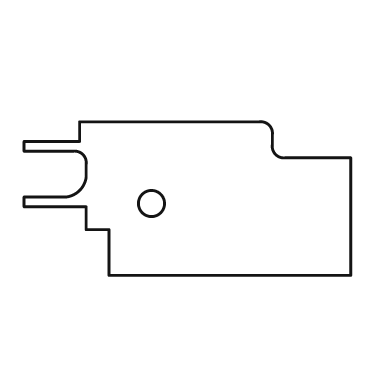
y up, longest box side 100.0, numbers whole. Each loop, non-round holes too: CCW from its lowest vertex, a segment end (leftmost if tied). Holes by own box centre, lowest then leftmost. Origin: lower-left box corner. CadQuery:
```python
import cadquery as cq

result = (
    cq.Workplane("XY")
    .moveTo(26.0, 0.0)
    .lineTo(100.0, 0.0)
    .lineTo(100.0, 36.0)
    .lineTo(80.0, 36.0)
    .threePointArc((77.0, 37.0), (76.0, 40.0))
    .lineTo(76.0, 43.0)
    .threePointArc((75.0, 46.0), (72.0, 47.0))
    .lineTo(17.0, 47.0)
    .lineTo(17.0, 41.0)
    .lineTo(0.0, 41.0)
    .lineTo(0.0, 38.0)
    .lineTo(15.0, 38.0)
    .threePointArc((18.0, 37.0), (19.0, 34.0))
    .lineTo(19.0, 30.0)
    .threePointArc((17.0, 26.0), (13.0, 24.0))
    .lineTo(0.0, 24.0)
    .lineTo(0.0, 21.0)
    .lineTo(19.0, 21.0)
    .lineTo(19.0, 14.0)
    .lineTo(26.0, 14.0)
    .close()
    .moveTo(39.0, 22.0)
    .circle(4.0)
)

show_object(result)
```